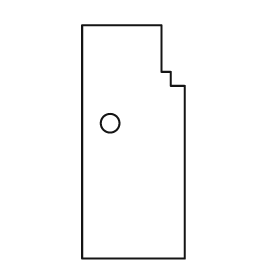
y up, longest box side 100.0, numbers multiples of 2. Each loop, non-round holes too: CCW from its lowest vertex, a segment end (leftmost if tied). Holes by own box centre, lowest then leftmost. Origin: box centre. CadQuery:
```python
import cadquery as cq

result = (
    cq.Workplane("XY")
    .moveTo(-22.0, -50.0)
    .lineTo(22.0, -50.0)
    .lineTo(22.0, 24.0)
    .lineTo(16.0, 24.0)
    .lineTo(16.0, 30.0)
    .lineTo(12.0, 30.0)
    .lineTo(12.0, 50.0)
    .lineTo(-22.0, 50.0)
    .close()
    .moveTo(-10.0, 8.0)
    .circle(4.0)
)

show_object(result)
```